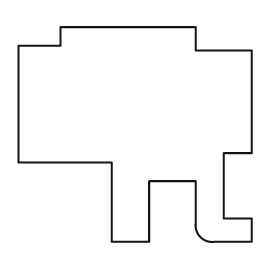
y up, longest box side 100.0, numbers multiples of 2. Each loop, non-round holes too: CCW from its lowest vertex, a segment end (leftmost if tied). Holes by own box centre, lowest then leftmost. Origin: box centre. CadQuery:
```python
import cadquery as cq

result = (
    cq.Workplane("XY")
    .moveTo(-10.0, -46.0)
    .lineTo(6.0, -46.0)
    .lineTo(6.0, -20.0)
    .lineTo(26.0, -20.0)
    .lineTo(26.0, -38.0)
    .threePointArc((28.0, -44.0), (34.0, -46.0))
    .lineTo(50.0, -46.0)
    .lineTo(50.0, -36.0)
    .lineTo(38.0, -36.0)
    .lineTo(38.0, -8.0)
    .lineTo(50.0, -8.0)
    .lineTo(50.0, 36.0)
    .lineTo(26.0, 36.0)
    .lineTo(26.0, 46.0)
    .lineTo(-32.0, 46.0)
    .lineTo(-32.0, 38.0)
    .lineTo(-50.0, 38.0)
    .lineTo(-50.0, -12.0)
    .lineTo(-10.0, -12.0)
    .close()
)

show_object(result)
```